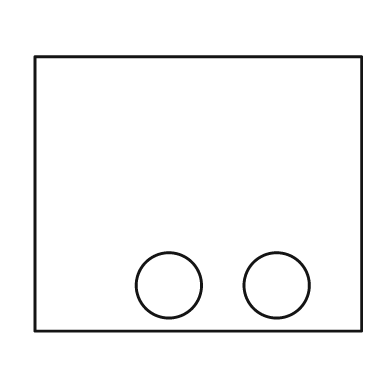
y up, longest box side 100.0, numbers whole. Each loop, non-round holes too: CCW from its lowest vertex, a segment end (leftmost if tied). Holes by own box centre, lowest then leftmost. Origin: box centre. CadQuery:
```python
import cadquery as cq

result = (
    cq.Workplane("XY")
    .moveTo(-50.0, -42.0)
    .lineTo(50.0, -42.0)
    .lineTo(50.0, 42.0)
    .lineTo(-50.0, 42.0)
    .close()
    .moveTo(-9.0, -28.0)
    .circle(10.0)
    .moveTo(24.0, -28.0)
    .circle(10.0)
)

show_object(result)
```